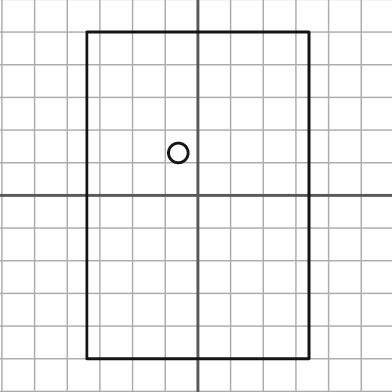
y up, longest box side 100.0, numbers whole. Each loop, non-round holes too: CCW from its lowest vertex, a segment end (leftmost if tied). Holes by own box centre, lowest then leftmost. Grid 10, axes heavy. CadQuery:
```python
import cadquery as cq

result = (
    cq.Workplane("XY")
    .moveTo(-34.0, -50.0)
    .lineTo(34.0, -50.0)
    .lineTo(34.0, 50.0)
    .lineTo(-34.0, 50.0)
    .close()
    .moveTo(-6.0, 13.0)
    .circle(3.0)
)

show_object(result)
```